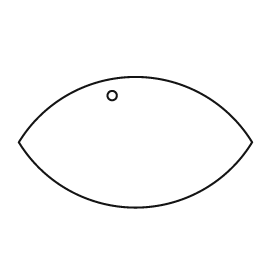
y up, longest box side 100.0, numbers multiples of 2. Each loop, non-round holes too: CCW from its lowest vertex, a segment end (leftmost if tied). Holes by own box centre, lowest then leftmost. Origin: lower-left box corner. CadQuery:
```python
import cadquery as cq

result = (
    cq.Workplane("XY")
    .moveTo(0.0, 28.0)
    .threePointArc((50.0, 0.0), (100.0, 28.0))
    .threePointArc((50.0, 56.0), (0.0, 28.0))
    .close()
    .moveTo(40.0, 48.0)
    .circle(2.0)
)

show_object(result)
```